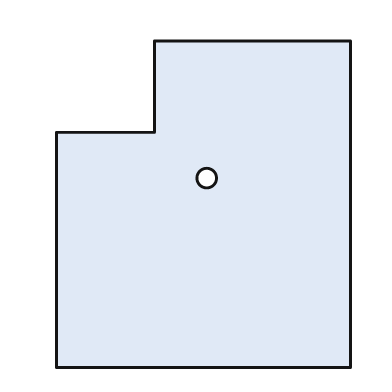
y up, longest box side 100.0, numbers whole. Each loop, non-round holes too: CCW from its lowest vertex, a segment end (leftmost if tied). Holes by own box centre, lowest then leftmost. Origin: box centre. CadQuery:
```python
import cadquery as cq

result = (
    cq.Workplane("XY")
    .moveTo(-45.0, -50.0)
    .lineTo(45.0, -50.0)
    .lineTo(45.0, 50.0)
    .lineTo(-15.0, 50.0)
    .lineTo(-15.0, 22.0)
    .lineTo(-45.0, 22.0)
    .close()
    .moveTo(1.0, 8.0)
    .circle(3.0)
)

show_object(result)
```